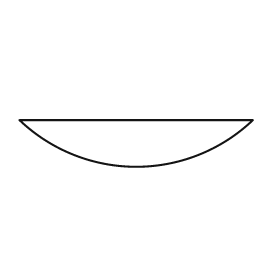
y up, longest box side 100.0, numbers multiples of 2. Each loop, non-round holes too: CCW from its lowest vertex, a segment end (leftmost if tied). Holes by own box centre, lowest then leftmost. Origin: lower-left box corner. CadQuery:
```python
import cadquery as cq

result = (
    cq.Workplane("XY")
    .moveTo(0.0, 20.0)
    .threePointArc((50.0, 0.0), (100.0, 20.0))
    .close()
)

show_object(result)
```